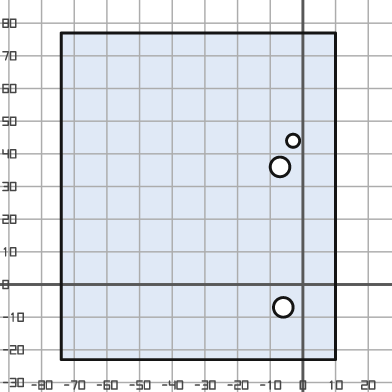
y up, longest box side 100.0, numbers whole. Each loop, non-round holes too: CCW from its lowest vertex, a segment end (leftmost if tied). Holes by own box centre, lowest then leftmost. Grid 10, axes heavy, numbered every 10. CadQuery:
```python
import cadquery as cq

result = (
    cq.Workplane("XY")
    .moveTo(-74.0, -23.0)
    .lineTo(10.0, -23.0)
    .lineTo(10.0, 77.0)
    .lineTo(-74.0, 77.0)
    .close()
    .moveTo(-6.0, -7.0)
    .circle(3.0)
    .moveTo(-7.0, 36.0)
    .circle(3.0)
    .moveTo(-3.0, 44.0)
    .circle(2.0)
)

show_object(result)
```